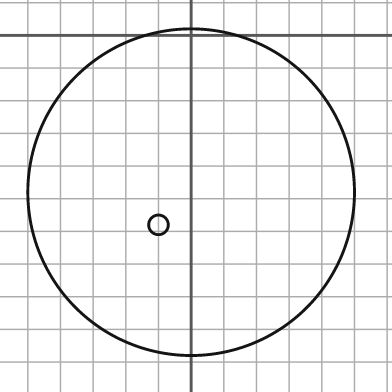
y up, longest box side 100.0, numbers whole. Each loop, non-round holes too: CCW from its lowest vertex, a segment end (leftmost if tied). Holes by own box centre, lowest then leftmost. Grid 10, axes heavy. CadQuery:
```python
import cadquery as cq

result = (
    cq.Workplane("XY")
    .moveTo(0.0, -48.0)
    .circle(50.0)
    .moveTo(-10.0, -58.0)
    .circle(3.0)
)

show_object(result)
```